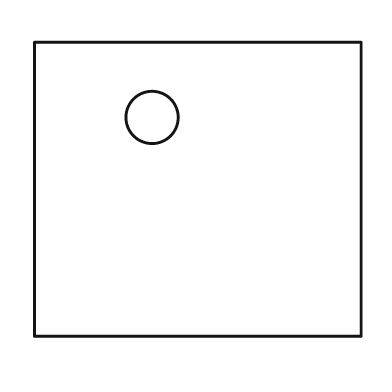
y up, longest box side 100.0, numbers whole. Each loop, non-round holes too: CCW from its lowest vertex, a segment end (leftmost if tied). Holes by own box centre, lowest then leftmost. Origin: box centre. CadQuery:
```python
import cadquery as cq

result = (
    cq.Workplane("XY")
    .moveTo(-50.0, -45.0)
    .lineTo(50.0, -45.0)
    .lineTo(50.0, 45.0)
    .lineTo(-50.0, 45.0)
    .close()
    .moveTo(-14.0, 22.0)
    .circle(8.0)
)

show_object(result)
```